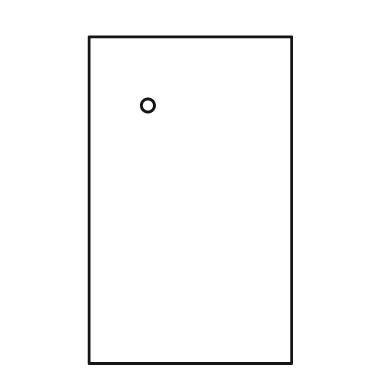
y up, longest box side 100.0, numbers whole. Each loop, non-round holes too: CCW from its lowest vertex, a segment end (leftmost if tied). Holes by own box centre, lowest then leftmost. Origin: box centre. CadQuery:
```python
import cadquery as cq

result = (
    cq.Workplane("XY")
    .moveTo(-31.0, -50.0)
    .lineTo(31.0, -50.0)
    .lineTo(31.0, 50.0)
    .lineTo(-31.0, 50.0)
    .close()
    .moveTo(-13.0, 29.0)
    .circle(2.0)
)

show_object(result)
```